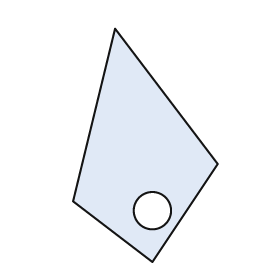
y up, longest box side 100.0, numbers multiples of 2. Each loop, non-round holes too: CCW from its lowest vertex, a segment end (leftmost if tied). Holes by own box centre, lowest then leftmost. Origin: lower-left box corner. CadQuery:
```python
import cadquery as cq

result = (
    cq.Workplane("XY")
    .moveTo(34.0, 0.0)
    .lineTo(62.0, 42.0)
    .lineTo(18.0, 100.0)
    .lineTo(0.0, 26.0)
    .close()
    .moveTo(34.0, 22.0)
    .circle(8.0)
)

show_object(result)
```